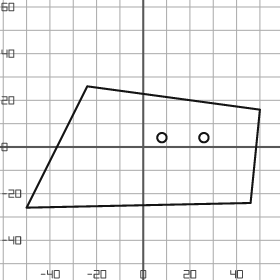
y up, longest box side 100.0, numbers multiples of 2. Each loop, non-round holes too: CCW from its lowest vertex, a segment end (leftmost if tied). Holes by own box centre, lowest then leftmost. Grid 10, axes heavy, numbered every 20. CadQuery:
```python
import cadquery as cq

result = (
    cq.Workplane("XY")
    .moveTo(-50.0, -26.0)
    .lineTo(46.0, -24.0)
    .lineTo(50.0, 16.0)
    .lineTo(-24.0, 26.0)
    .close()
    .moveTo(8.0, 4.0)
    .circle(2.0)
    .moveTo(26.0, 4.0)
    .circle(2.0)
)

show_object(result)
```